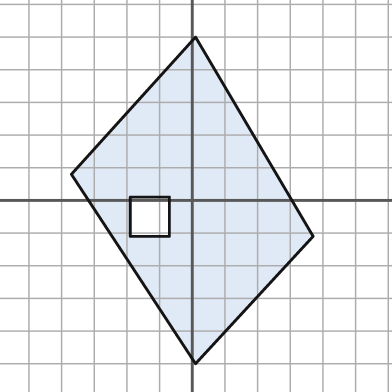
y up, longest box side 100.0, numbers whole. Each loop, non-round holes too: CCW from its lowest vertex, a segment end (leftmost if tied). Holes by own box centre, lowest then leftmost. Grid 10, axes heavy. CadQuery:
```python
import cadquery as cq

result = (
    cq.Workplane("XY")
    .moveTo(1.0, -50.0)
    .lineTo(37.0, -11.0)
    .lineTo(1.0, 50.0)
    .lineTo(-37.0, 8.0)
    .close()
    .moveTo(-19.0, -11.0)
    .lineTo(-7.0, -11.0)
    .lineTo(-7.0, 1.0)
    .lineTo(-19.0, 1.0)
    .close()
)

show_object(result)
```